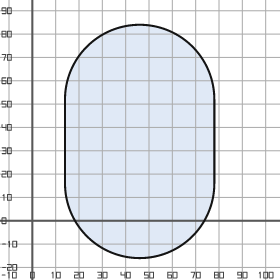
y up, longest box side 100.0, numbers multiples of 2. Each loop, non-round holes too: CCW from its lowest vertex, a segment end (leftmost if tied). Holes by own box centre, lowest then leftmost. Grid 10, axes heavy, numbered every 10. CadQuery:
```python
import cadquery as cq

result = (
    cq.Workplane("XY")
    .moveTo(14.0, 16.0)
    .threePointArc((46.0, -16.0), (78.0, 16.0))
    .lineTo(78.0, 52.0)
    .threePointArc((46.0, 84.0), (14.0, 52.0))
    .close()
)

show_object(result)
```